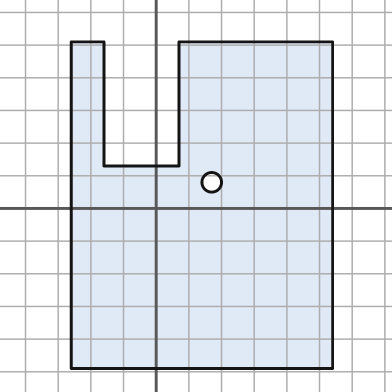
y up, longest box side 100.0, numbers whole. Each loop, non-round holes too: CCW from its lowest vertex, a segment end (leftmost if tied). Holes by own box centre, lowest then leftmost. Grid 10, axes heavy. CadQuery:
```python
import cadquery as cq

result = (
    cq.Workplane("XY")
    .moveTo(-26.0, -49.0)
    .lineTo(54.0, -49.0)
    .lineTo(54.0, 51.0)
    .lineTo(7.0, 51.0)
    .lineTo(7.0, 13.0)
    .lineTo(-16.0, 13.0)
    .lineTo(-16.0, 51.0)
    .lineTo(-26.0, 51.0)
    .close()
    .moveTo(17.0, 8.0)
    .circle(3.0)
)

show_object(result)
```